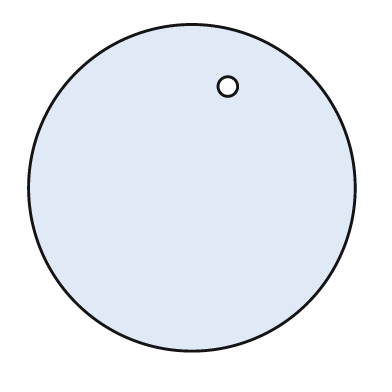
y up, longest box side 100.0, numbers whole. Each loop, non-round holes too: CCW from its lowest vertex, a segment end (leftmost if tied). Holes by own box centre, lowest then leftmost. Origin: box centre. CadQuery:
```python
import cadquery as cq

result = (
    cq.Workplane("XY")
    .moveTo(0.0, 0.0)
    .circle(50.0)
    .moveTo(11.0, 31.0)
    .circle(3.0)
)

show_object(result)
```